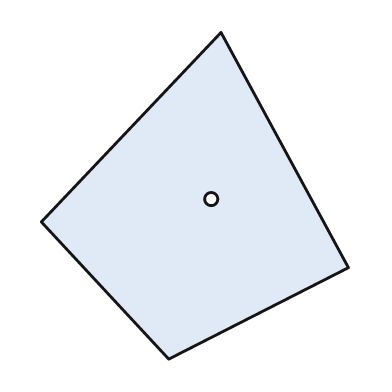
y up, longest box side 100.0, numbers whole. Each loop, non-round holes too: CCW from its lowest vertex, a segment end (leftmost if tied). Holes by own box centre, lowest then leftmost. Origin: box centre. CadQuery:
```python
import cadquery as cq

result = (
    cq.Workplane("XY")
    .moveTo(-8.0, -50.0)
    .lineTo(47.0, -22.0)
    .lineTo(8.0, 50.0)
    .lineTo(-47.0, -8.0)
    .close()
    .moveTo(5.0, -1.0)
    .circle(2.0)
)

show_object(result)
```